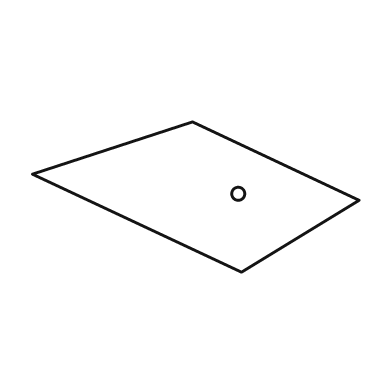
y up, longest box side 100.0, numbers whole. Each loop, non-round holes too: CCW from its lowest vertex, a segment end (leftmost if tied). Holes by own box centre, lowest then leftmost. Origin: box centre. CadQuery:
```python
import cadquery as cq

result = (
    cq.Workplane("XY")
    .moveTo(14.0, -23.0)
    .lineTo(50.0, -1.0)
    .lineTo(-1.0, 23.0)
    .lineTo(-50.0, 7.0)
    .close()
    .moveTo(13.0, 1.0)
    .circle(2.0)
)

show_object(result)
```